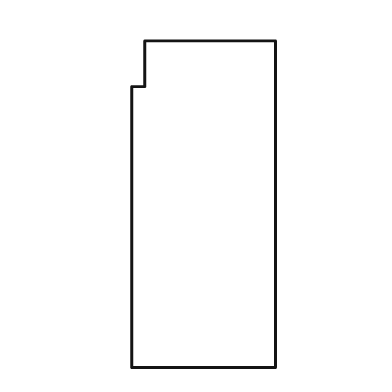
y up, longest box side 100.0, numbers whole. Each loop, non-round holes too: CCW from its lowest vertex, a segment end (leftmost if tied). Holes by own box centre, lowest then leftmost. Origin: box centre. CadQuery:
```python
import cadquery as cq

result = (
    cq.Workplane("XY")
    .moveTo(-22.0, -50.0)
    .lineTo(22.0, -50.0)
    .lineTo(22.0, 50.0)
    .lineTo(-18.0, 50.0)
    .lineTo(-18.0, 36.0)
    .lineTo(-22.0, 36.0)
    .close()
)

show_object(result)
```